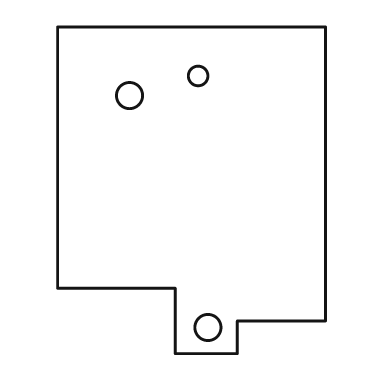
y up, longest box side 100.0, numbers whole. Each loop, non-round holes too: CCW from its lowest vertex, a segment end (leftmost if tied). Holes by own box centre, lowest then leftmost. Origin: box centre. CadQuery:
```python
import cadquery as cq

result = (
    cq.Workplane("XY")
    .moveTo(-5.0, -50.0)
    .lineTo(14.0, -50.0)
    .lineTo(14.0, -40.0)
    .lineTo(41.0, -40.0)
    .lineTo(41.0, 50.0)
    .lineTo(-41.0, 50.0)
    .lineTo(-41.0, -30.0)
    .lineTo(-5.0, -30.0)
    .close()
    .moveTo(5.0, -42.0)
    .circle(4.0)
    .moveTo(-19.0, 29.0)
    .circle(4.0)
    .moveTo(2.0, 35.0)
    .circle(3.0)
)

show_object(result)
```